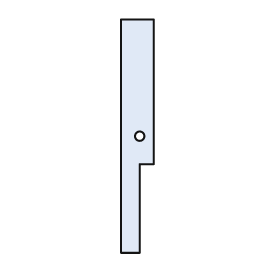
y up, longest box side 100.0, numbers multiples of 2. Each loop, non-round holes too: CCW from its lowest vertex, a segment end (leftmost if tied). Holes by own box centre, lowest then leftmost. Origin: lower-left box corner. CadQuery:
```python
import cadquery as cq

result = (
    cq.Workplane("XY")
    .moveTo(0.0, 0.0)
    .lineTo(8.0, 0.0)
    .lineTo(8.0, 38.0)
    .lineTo(14.0, 38.0)
    .lineTo(14.0, 100.0)
    .lineTo(0.0, 100.0)
    .close()
    .moveTo(8.0, 50.0)
    .circle(2.0)
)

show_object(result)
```